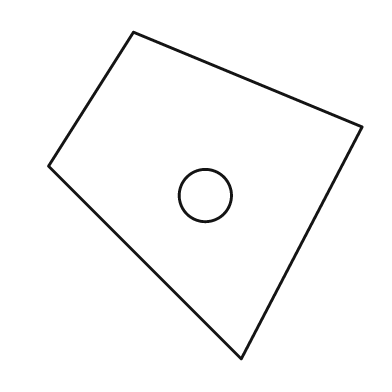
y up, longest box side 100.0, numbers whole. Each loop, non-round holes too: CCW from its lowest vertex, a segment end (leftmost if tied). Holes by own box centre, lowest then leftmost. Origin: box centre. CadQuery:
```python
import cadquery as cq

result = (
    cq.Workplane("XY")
    .moveTo(11.0, -50.0)
    .lineTo(48.0, 21.0)
    .lineTo(-22.0, 50.0)
    .lineTo(-48.0, 9.0)
    .close()
    .moveTo(0.0, 0.0)
    .circle(8.0)
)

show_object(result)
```